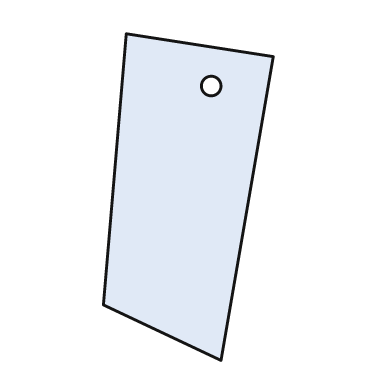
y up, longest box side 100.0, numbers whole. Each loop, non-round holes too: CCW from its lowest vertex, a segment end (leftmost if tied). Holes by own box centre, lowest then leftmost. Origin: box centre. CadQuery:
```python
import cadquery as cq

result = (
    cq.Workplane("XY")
    .moveTo(10.0, -50.0)
    .lineTo(26.0, 43.0)
    .lineTo(-19.0, 50.0)
    .lineTo(-26.0, -33.0)
    .close()
    .moveTo(7.0, 34.0)
    .circle(3.0)
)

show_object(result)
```